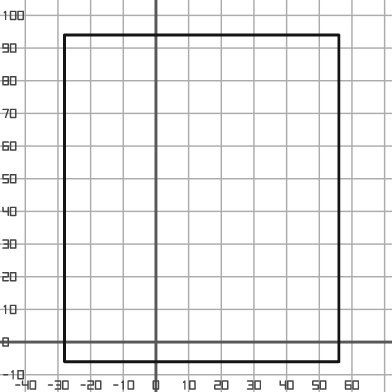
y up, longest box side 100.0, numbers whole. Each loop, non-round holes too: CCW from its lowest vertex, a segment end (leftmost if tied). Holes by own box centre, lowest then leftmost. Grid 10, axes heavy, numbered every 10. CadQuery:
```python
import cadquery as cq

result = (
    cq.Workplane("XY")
    .moveTo(-28.0, -6.0)
    .lineTo(56.0, -6.0)
    .lineTo(56.0, 94.0)
    .lineTo(-28.0, 94.0)
    .close()
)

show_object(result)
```